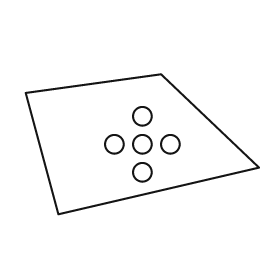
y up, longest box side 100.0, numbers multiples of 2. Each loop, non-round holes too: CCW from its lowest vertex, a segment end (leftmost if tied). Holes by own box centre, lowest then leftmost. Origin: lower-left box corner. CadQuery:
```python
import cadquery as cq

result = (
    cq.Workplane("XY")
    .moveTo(14.0, 0.0)
    .lineTo(100.0, 20.0)
    .lineTo(58.0, 60.0)
    .lineTo(0.0, 52.0)
    .close()
    .moveTo(50.0, 18.0)
    .circle(4.0)
    .moveTo(38.0, 30.0)
    .circle(4.0)
    .moveTo(50.0, 30.0)
    .circle(4.0)
    .moveTo(62.0, 30.0)
    .circle(4.0)
    .moveTo(50.0, 42.0)
    .circle(4.0)
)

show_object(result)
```